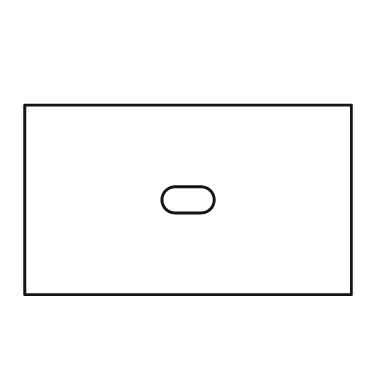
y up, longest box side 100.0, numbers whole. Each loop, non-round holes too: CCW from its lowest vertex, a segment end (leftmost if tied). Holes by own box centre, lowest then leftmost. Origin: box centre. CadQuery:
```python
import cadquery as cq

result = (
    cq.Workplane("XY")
    .moveTo(-50.0, -29.0)
    .lineTo(50.0, -29.0)
    .lineTo(50.0, 29.0)
    .lineTo(-50.0, 29.0)
    .close()
    .moveTo(-4.0, -4.0)
    .lineTo(4.0, -4.0)
    .threePointArc((8.0, 0.0), (4.0, 4.0))
    .lineTo(-4.0, 4.0)
    .threePointArc((-8.0, 0.0), (-4.0, -4.0))
    .close()
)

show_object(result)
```